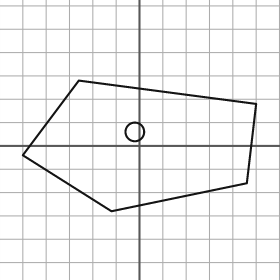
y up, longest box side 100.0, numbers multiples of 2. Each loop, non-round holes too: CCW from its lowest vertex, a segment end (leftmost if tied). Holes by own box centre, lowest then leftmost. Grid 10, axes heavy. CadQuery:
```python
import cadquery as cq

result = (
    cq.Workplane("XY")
    .moveTo(-12.0, -28.0)
    .lineTo(46.0, -16.0)
    .lineTo(50.0, 18.0)
    .lineTo(-26.0, 28.0)
    .lineTo(-50.0, -4.0)
    .close()
    .moveTo(-2.0, 6.0)
    .circle(4.0)
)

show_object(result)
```